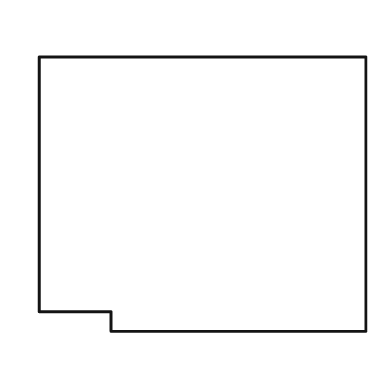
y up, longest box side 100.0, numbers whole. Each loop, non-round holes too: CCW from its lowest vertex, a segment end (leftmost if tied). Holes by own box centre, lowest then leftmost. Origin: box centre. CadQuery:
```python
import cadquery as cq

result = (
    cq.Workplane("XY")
    .moveTo(-28.0, -42.0)
    .lineTo(50.0, -42.0)
    .lineTo(50.0, 42.0)
    .lineTo(-50.0, 42.0)
    .lineTo(-50.0, -36.0)
    .lineTo(-28.0, -36.0)
    .close()
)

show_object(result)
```